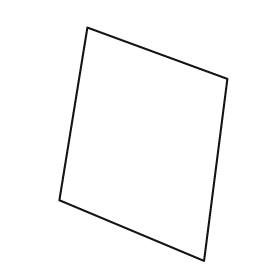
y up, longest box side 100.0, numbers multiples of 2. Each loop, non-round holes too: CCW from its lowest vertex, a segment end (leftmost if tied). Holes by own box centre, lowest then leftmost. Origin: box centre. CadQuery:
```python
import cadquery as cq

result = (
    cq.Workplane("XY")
    .moveTo(26.0, -50.0)
    .lineTo(36.0, 28.0)
    .lineTo(-24.0, 50.0)
    .lineTo(-36.0, -24.0)
    .close()
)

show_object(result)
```